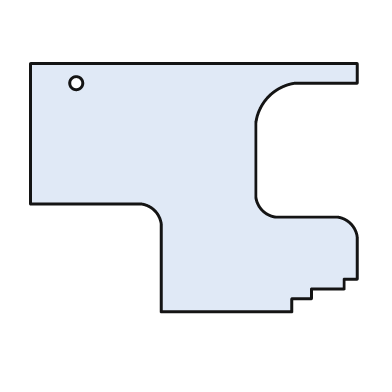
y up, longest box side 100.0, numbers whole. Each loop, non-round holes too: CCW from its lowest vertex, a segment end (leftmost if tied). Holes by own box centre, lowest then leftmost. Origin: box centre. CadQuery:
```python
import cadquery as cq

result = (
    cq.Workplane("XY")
    .moveTo(-10.0, -38.0)
    .lineTo(30.0, -38.0)
    .lineTo(30.0, -34.0)
    .lineTo(36.0, -34.0)
    .lineTo(36.0, -31.0)
    .lineTo(46.0, -31.0)
    .lineTo(46.0, -28.0)
    .lineTo(50.0, -28.0)
    .lineTo(50.0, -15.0)
    .threePointArc((48.0, -11.0), (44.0, -9.0))
    .lineTo(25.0, -9.0)
    .threePointArc((21.0, -7.0), (19.0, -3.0))
    .lineTo(19.0, 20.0)
    .threePointArc((23.0, 28.0), (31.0, 32.0))
    .lineTo(50.0, 32.0)
    .lineTo(50.0, 38.0)
    .lineTo(-50.0, 38.0)
    .lineTo(-50.0, -5.0)
    .lineTo(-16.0, -5.0)
    .threePointArc((-12.0, -7.0), (-10.0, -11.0))
    .close()
    .moveTo(-36.0, 32.0)
    .circle(2.0)
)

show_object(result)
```